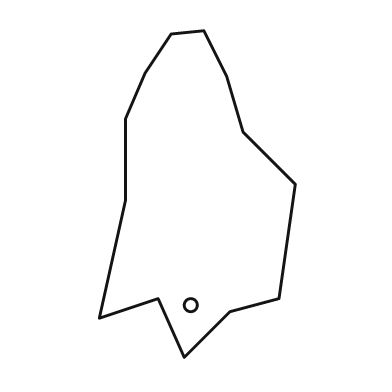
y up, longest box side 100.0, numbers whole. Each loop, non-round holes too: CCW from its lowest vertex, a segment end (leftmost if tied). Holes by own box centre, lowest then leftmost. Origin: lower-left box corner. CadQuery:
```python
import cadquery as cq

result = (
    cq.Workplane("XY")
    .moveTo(26.0, 0.0)
    .lineTo(40.0, 14.0)
    .lineTo(55.0, 18.0)
    .lineTo(60.0, 53.0)
    .lineTo(44.0, 69.0)
    .lineTo(39.0, 86.0)
    .lineTo(32.0, 100.0)
    .lineTo(22.0, 99.0)
    .lineTo(14.0, 87.0)
    .lineTo(8.0, 73.0)
    .lineTo(8.0, 48.0)
    .lineTo(0.0, 12.0)
    .lineTo(18.0, 18.0)
    .close()
    .moveTo(28.0, 16.0)
    .circle(2.0)
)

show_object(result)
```